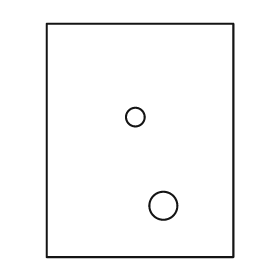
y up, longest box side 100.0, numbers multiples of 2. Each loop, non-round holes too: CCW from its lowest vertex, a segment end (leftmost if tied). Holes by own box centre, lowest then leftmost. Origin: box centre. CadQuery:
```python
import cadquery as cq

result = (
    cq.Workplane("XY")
    .moveTo(-40.0, -50.0)
    .lineTo(40.0, -50.0)
    .lineTo(40.0, 50.0)
    .lineTo(-40.0, 50.0)
    .close()
    .moveTo(10.0, -28.0)
    .circle(6.0)
    .moveTo(-2.0, 10.0)
    .circle(4.0)
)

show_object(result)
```